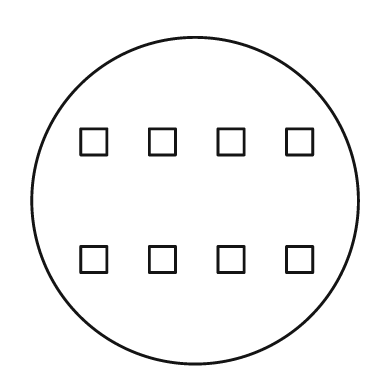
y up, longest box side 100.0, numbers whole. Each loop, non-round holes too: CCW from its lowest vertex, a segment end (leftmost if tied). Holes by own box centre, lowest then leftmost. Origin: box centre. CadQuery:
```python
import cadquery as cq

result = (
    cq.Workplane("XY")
    .moveTo(0.0, 0.0)
    .circle(50.0)
    .moveTo(-35.0, -22.0)
    .lineTo(-27.0, -22.0)
    .lineTo(-27.0, -14.0)
    .lineTo(-35.0, -14.0)
    .close()
    .moveTo(-14.0, -22.0)
    .lineTo(-6.0, -22.0)
    .lineTo(-6.0, -14.0)
    .lineTo(-14.0, -14.0)
    .close()
    .moveTo(7.0, -22.0)
    .lineTo(15.0, -22.0)
    .lineTo(15.0, -14.0)
    .lineTo(7.0, -14.0)
    .close()
    .moveTo(28.0, -22.0)
    .lineTo(36.0, -22.0)
    .lineTo(36.0, -14.0)
    .lineTo(28.0, -14.0)
    .close()
    .moveTo(-35.0, 14.0)
    .lineTo(-27.0, 14.0)
    .lineTo(-27.0, 22.0)
    .lineTo(-35.0, 22.0)
    .close()
    .moveTo(-14.0, 14.0)
    .lineTo(-6.0, 14.0)
    .lineTo(-6.0, 22.0)
    .lineTo(-14.0, 22.0)
    .close()
    .moveTo(7.0, 14.0)
    .lineTo(15.0, 14.0)
    .lineTo(15.0, 22.0)
    .lineTo(7.0, 22.0)
    .close()
    .moveTo(28.0, 14.0)
    .lineTo(36.0, 14.0)
    .lineTo(36.0, 22.0)
    .lineTo(28.0, 22.0)
    .close()
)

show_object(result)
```